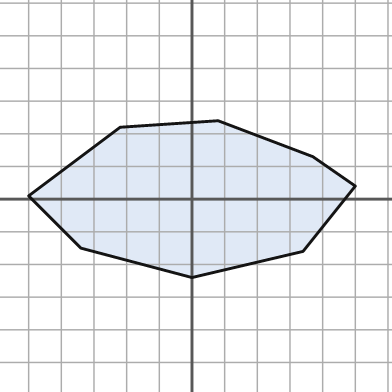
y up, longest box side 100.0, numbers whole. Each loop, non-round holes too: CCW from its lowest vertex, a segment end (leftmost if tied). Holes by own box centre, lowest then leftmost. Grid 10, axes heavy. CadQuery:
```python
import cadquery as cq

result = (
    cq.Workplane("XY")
    .moveTo(0.0, -24.0)
    .lineTo(34.0, -16.0)
    .lineTo(50.0, 4.0)
    .lineTo(37.0, 13.0)
    .lineTo(8.0, 24.0)
    .lineTo(-22.0, 22.0)
    .lineTo(-50.0, 1.0)
    .lineTo(-34.0, -15.0)
    .close()
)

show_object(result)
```